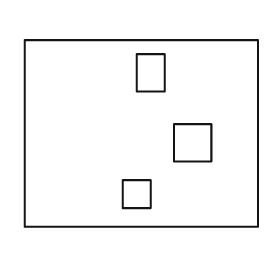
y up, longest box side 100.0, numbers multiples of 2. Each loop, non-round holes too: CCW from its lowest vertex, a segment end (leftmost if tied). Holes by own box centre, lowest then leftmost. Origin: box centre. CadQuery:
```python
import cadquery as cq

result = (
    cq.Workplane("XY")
    .moveTo(-50.0, -40.0)
    .lineTo(50.0, -40.0)
    .lineTo(50.0, 40.0)
    .lineTo(-50.0, 40.0)
    .close()
    .moveTo(-8.0, -32.0)
    .lineTo(4.0, -32.0)
    .lineTo(4.0, -20.0)
    .lineTo(-8.0, -20.0)
    .close()
    .moveTo(14.0, -12.0)
    .lineTo(30.0, -12.0)
    .lineTo(30.0, 4.0)
    .lineTo(14.0, 4.0)
    .close()
    .moveTo(-2.0, 18.0)
    .lineTo(10.0, 18.0)
    .lineTo(10.0, 34.0)
    .lineTo(-2.0, 34.0)
    .close()
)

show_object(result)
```